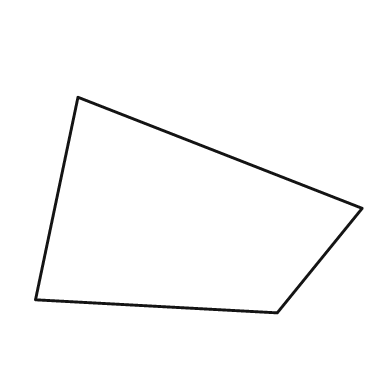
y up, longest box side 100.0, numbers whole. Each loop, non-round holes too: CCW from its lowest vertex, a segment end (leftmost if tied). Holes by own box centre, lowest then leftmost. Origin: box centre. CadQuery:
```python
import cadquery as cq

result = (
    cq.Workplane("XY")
    .moveTo(24.0, -33.0)
    .lineTo(50.0, -1.0)
    .lineTo(-37.0, 33.0)
    .lineTo(-50.0, -29.0)
    .close()
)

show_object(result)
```